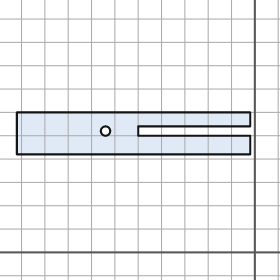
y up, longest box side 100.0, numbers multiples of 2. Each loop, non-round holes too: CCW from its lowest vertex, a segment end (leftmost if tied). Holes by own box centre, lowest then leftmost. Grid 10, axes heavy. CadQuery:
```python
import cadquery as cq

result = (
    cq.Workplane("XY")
    .moveTo(-102.0, 42.0)
    .lineTo(-2.0, 42.0)
    .lineTo(-2.0, 50.0)
    .lineTo(-50.0, 50.0)
    .lineTo(-50.0, 54.0)
    .lineTo(-2.0, 54.0)
    .lineTo(-2.0, 60.0)
    .lineTo(-102.0, 60.0)
    .close()
    .moveTo(-64.0, 52.0)
    .circle(2.0)
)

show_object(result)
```